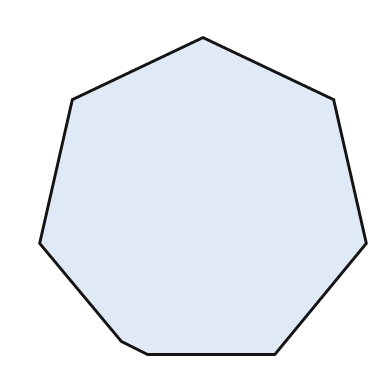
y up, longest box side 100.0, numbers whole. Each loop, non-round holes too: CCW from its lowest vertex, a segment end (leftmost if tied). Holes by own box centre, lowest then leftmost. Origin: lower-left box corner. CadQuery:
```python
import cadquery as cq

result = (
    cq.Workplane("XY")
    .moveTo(33.0, 0.0)
    .lineTo(72.0, 0.0)
    .lineTo(100.0, 34.0)
    .lineTo(90.0, 78.0)
    .lineTo(50.0, 97.0)
    .lineTo(10.0, 78.0)
    .lineTo(0.0, 34.0)
    .lineTo(25.0, 4.0)
    .close()
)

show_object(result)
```